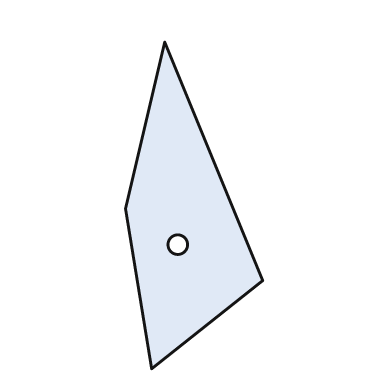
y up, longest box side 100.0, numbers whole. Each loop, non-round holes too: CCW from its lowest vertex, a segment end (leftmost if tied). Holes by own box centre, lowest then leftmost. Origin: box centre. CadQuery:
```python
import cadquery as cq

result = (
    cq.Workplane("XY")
    .moveTo(-13.0, -50.0)
    .lineTo(21.0, -23.0)
    .lineTo(-9.0, 50.0)
    .lineTo(-21.0, -1.0)
    .close()
    .moveTo(-5.0, -12.0)
    .circle(3.0)
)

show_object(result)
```